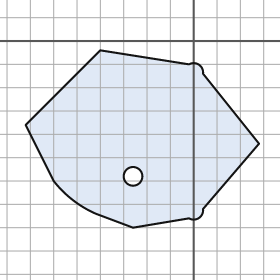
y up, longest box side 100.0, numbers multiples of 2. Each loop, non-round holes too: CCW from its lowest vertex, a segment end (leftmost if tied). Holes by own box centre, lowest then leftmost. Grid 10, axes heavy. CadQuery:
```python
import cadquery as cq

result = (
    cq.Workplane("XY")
    .moveTo(-26.0, -80.0)
    .lineTo(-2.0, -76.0)
    .threePointArc((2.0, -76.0), (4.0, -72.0))
    .lineTo(28.0, -44.0)
    .lineTo(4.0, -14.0)
    .threePointArc((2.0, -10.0), (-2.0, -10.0))
    .lineTo(-40.0, -4.0)
    .lineTo(-72.0, -36.0)
    .lineTo(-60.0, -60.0)
    .threePointArc((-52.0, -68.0), (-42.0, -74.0))
    .close()
    .moveTo(-26.0, -58.0)
    .circle(4.0)
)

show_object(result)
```